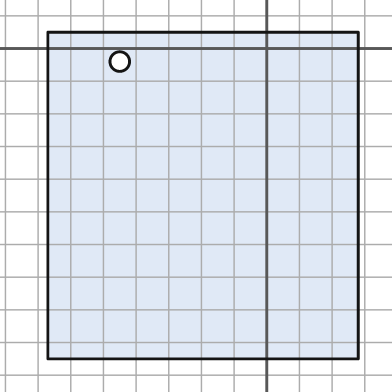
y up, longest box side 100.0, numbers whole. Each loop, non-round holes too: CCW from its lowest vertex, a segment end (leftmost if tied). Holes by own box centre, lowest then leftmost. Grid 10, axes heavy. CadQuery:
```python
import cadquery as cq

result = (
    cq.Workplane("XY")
    .moveTo(-67.0, -95.0)
    .lineTo(28.0, -95.0)
    .lineTo(28.0, 5.0)
    .lineTo(-67.0, 5.0)
    .close()
    .moveTo(-45.0, -4.0)
    .circle(3.0)
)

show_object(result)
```